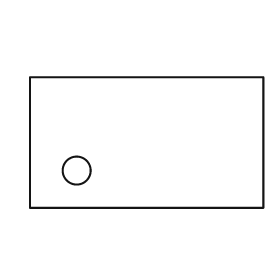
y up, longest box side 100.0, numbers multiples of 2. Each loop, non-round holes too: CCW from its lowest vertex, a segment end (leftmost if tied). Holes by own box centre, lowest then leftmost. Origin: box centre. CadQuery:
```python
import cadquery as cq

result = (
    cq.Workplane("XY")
    .moveTo(-50.0, -28.0)
    .lineTo(50.0, -28.0)
    .lineTo(50.0, 28.0)
    .lineTo(-50.0, 28.0)
    .close()
    .moveTo(-30.0, -12.0)
    .circle(6.0)
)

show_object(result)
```